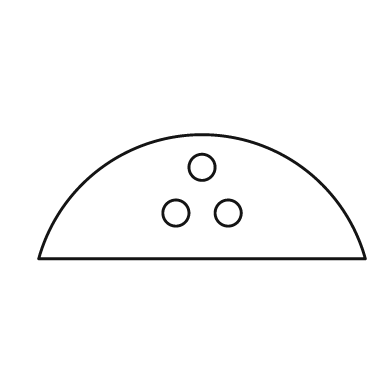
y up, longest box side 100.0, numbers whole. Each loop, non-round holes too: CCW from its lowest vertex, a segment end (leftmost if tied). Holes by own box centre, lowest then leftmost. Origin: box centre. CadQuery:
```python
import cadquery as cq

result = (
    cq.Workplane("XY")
    .moveTo(-50.0, -19.0)
    .lineTo(50.0, -19.0)
    .threePointArc((0.0, 19.0), (-50.0, -19.0))
    .close()
    .moveTo(-8.0, -5.0)
    .circle(4.0)
    .moveTo(8.0, -5.0)
    .circle(4.0)
    .moveTo(0.0, 9.0)
    .circle(4.0)
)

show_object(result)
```